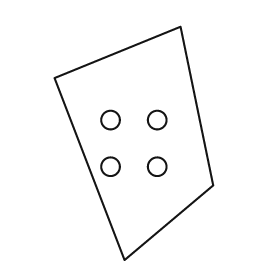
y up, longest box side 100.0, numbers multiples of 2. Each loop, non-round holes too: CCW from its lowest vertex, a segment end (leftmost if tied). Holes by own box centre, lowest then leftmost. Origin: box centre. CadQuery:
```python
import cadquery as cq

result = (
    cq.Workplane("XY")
    .moveTo(-4.0, -50.0)
    .lineTo(34.0, -18.0)
    .lineTo(20.0, 50.0)
    .lineTo(-34.0, 28.0)
    .close()
    .moveTo(-10.0, -10.0)
    .circle(4.0)
    .moveTo(10.0, -10.0)
    .circle(4.0)
    .moveTo(-10.0, 10.0)
    .circle(4.0)
    .moveTo(10.0, 10.0)
    .circle(4.0)
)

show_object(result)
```